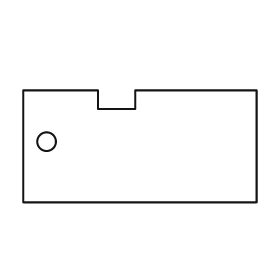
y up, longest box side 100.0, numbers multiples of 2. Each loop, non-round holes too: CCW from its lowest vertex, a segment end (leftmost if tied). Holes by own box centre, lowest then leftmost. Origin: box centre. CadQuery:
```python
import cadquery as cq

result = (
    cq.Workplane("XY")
    .moveTo(-50.0, -24.0)
    .lineTo(50.0, -24.0)
    .lineTo(50.0, 24.0)
    .lineTo(-2.0, 24.0)
    .lineTo(-2.0, 16.0)
    .lineTo(-18.0, 16.0)
    .lineTo(-18.0, 24.0)
    .lineTo(-50.0, 24.0)
    .close()
    .moveTo(-40.0, 2.0)
    .circle(4.0)
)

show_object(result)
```